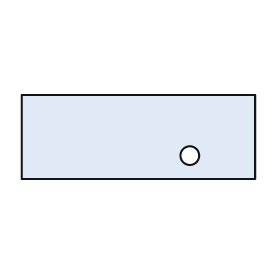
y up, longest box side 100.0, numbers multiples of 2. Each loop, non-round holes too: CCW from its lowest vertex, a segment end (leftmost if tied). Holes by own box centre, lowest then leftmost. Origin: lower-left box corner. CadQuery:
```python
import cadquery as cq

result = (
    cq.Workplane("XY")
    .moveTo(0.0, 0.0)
    .lineTo(100.0, 0.0)
    .lineTo(100.0, 36.0)
    .lineTo(0.0, 36.0)
    .close()
    .moveTo(72.0, 10.0)
    .circle(4.0)
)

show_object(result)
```